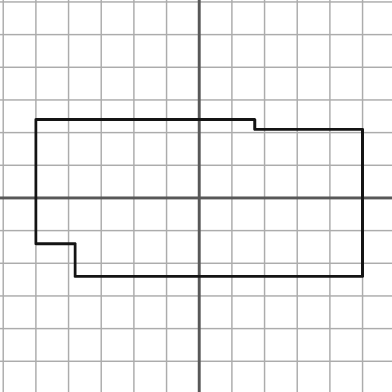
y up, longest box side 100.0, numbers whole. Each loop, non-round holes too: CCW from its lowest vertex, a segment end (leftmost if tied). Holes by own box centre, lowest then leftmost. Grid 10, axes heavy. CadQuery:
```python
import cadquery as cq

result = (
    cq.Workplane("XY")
    .moveTo(-38.0, -24.0)
    .lineTo(50.0, -24.0)
    .lineTo(50.0, 21.0)
    .lineTo(17.0, 21.0)
    .lineTo(17.0, 24.0)
    .lineTo(-50.0, 24.0)
    .lineTo(-50.0, -14.0)
    .lineTo(-38.0, -14.0)
    .close()
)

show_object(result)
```